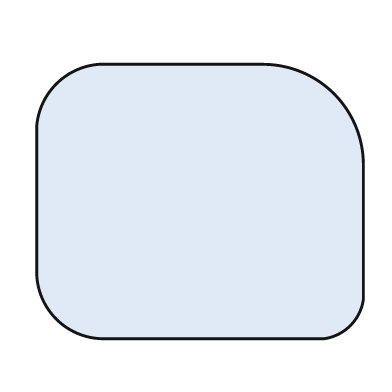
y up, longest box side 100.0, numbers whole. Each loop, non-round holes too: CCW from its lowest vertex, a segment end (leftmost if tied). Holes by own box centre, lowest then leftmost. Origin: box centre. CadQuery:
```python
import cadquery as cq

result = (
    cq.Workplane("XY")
    .moveTo(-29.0, -42.0)
    .lineTo(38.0, -42.0)
    .threePointArc((46.0, -38.0), (50.0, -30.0))
    .lineTo(50.0, 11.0)
    .threePointArc((41.0, 33.0), (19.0, 42.0))
    .lineTo(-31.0, 42.0)
    .threePointArc((-44.0, 36.0), (-50.0, 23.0))
    .lineTo(-50.0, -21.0)
    .threePointArc((-44.0, -36.0), (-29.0, -42.0))
    .close()
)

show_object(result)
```